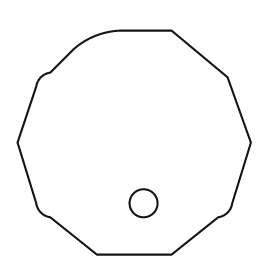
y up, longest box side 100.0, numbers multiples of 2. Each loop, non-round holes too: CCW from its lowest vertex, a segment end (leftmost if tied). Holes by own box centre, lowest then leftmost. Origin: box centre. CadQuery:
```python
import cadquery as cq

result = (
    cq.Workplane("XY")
    .moveTo(-16.0, -48.0)
    .lineTo(16.0, -48.0)
    .lineTo(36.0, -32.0)
    .threePointArc((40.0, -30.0), (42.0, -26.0))
    .lineTo(50.0, 0.0)
    .lineTo(40.0, 28.0)
    .lineTo(16.0, 48.0)
    .lineTo(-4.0, 48.0)
    .threePointArc((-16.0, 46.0), (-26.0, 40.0))
    .lineTo(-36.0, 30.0)
    .threePointArc((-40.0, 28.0), (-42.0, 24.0))
    .lineTo(-50.0, 0.0)
    .lineTo(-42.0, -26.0)
    .threePointArc((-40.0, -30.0), (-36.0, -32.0))
    .close()
    .moveTo(4.0, -26.0)
    .circle(6.0)
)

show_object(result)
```